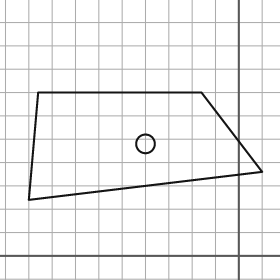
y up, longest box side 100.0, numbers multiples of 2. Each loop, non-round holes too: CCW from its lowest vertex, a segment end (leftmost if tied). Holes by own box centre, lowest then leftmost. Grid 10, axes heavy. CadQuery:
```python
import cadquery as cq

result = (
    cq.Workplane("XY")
    .moveTo(-90.0, 24.0)
    .lineTo(10.0, 36.0)
    .lineTo(-16.0, 70.0)
    .lineTo(-86.0, 70.0)
    .close()
    .moveTo(-40.0, 48.0)
    .circle(4.0)
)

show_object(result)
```